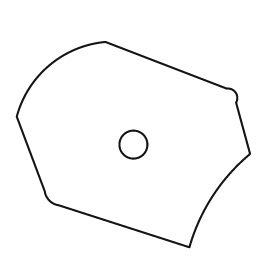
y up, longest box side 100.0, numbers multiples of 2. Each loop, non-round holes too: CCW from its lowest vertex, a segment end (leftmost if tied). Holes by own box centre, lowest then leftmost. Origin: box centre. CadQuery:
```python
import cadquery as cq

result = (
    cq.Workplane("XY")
    .moveTo(24.0, -44.0)
    .threePointArc((34.0, -22.0), (50.0, -4.0))
    .lineTo(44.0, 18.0)
    .threePointArc((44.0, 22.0), (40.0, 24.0))
    .lineTo(-12.0, 44.0)
    .threePointArc((-36.0, 34.0), (-50.0, 12.0))
    .lineTo(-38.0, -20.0)
    .threePointArc((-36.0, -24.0), (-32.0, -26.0))
    .close()
    .moveTo(0.0, 0.0)
    .circle(6.0)
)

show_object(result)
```